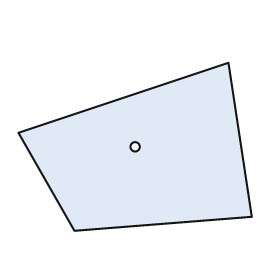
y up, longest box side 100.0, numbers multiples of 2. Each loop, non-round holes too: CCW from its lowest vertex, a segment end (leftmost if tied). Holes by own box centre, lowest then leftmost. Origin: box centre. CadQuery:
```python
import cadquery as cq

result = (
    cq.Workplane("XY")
    .moveTo(-26.0, -36.0)
    .lineTo(50.0, -30.0)
    .lineTo(40.0, 36.0)
    .lineTo(-50.0, 6.0)
    .close()
    .moveTo(0.0, 0.0)
    .circle(2.0)
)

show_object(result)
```